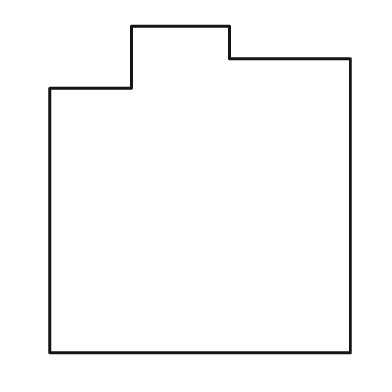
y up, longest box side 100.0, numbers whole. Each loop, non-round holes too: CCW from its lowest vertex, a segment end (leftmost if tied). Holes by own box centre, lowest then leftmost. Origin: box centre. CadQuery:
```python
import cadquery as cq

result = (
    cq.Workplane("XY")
    .moveTo(-46.0, -50.0)
    .lineTo(46.0, -50.0)
    .lineTo(46.0, 40.0)
    .lineTo(9.0, 40.0)
    .lineTo(9.0, 50.0)
    .lineTo(-21.0, 50.0)
    .lineTo(-21.0, 31.0)
    .lineTo(-46.0, 31.0)
    .close()
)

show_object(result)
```